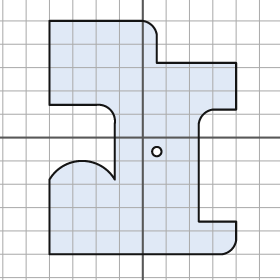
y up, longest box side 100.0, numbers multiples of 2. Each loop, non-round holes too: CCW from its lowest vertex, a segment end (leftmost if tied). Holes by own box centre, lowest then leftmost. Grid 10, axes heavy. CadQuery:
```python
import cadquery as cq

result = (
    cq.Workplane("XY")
    .moveTo(-40.0, -50.0)
    .lineTo(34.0, -50.0)
    .threePointArc((38.0, -48.0), (40.0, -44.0))
    .lineTo(40.0, -36.0)
    .lineTo(24.0, -36.0)
    .lineTo(24.0, 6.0)
    .threePointArc((26.0, 10.0), (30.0, 12.0))
    .lineTo(40.0, 12.0)
    .lineTo(40.0, 32.0)
    .lineTo(6.0, 32.0)
    .lineTo(6.0, 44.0)
    .threePointArc((4.0, 48.0), (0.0, 50.0))
    .lineTo(-40.0, 50.0)
    .lineTo(-40.0, 14.0)
    .lineTo(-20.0, 14.0)
    .threePointArc((-14.0, 12.0), (-12.0, 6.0))
    .lineTo(-12.0, -18.0)
    .threePointArc((-26.0, -10.0), (-40.0, -18.0))
    .close()
    .moveTo(6.0, -6.0)
    .circle(2.0)
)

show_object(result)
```